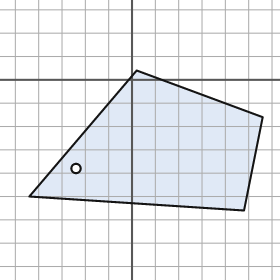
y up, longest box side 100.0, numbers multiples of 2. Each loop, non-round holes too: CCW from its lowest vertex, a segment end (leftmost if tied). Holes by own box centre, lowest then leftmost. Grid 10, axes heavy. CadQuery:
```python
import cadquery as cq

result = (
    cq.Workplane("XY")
    .moveTo(48.0, -56.0)
    .lineTo(56.0, -16.0)
    .lineTo(2.0, 4.0)
    .lineTo(-44.0, -50.0)
    .close()
    .moveTo(-24.0, -38.0)
    .circle(2.0)
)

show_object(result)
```